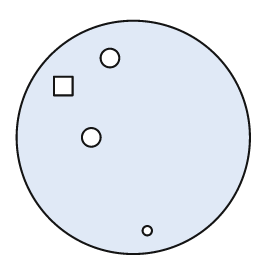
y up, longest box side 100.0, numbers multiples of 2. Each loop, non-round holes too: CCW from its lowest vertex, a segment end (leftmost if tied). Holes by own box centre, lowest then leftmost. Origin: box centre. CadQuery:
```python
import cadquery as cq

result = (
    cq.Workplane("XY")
    .moveTo(0.0, 0.0)
    .circle(50.0)
    .moveTo(6.0, -40.0)
    .circle(2.0)
    .moveTo(-18.0, 0.0)
    .circle(4.0)
    .moveTo(-34.0, 18.0)
    .lineTo(-26.0, 18.0)
    .lineTo(-26.0, 26.0)
    .lineTo(-34.0, 26.0)
    .close()
    .moveTo(-10.0, 34.0)
    .circle(4.0)
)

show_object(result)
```